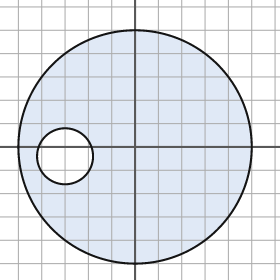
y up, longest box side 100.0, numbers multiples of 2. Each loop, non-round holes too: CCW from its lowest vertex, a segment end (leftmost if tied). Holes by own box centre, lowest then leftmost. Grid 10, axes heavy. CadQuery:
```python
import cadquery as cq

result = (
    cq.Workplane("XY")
    .moveTo(0.0, 0.0)
    .circle(50.0)
    .moveTo(-30.0, -4.0)
    .circle(12.0)
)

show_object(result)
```